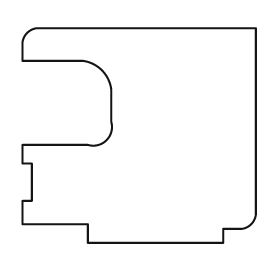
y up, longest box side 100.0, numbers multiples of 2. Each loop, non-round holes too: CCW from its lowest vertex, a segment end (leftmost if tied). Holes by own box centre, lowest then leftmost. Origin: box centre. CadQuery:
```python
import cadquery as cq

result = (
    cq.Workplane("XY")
    .moveTo(-22.0, -46.0)
    .lineTo(36.0, -46.0)
    .lineTo(36.0, -40.0)
    .lineTo(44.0, -40.0)
    .threePointArc((48.0, -38.0), (50.0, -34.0))
    .lineTo(50.0, 46.0)
    .lineTo(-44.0, 46.0)
    .threePointArc((-48.0, 44.0), (-50.0, 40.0))
    .lineTo(-50.0, 32.0)
    .lineTo(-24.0, 32.0)
    .threePointArc((-16.0, 28.0), (-12.0, 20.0))
    .lineTo(-12.0, 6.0)
    .threePointArc((-14.0, -2.0), (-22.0, -4.0))
    .lineTo(-50.0, -4.0)
    .lineTo(-50.0, -12.0)
    .lineTo(-46.0, -12.0)
    .lineTo(-46.0, -28.0)
    .lineTo(-50.0, -28.0)
    .lineTo(-50.0, -38.0)
    .lineTo(-22.0, -38.0)
    .close()
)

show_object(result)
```